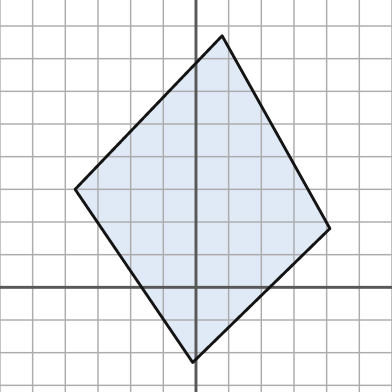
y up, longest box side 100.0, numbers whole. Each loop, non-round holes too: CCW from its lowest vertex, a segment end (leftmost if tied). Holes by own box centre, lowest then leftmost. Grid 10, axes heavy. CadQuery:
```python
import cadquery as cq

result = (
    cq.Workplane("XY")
    .moveTo(-1.0, -23.0)
    .lineTo(41.0, 18.0)
    .lineTo(8.0, 77.0)
    .lineTo(-37.0, 30.0)
    .close()
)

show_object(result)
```